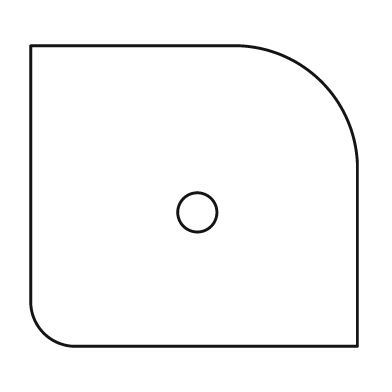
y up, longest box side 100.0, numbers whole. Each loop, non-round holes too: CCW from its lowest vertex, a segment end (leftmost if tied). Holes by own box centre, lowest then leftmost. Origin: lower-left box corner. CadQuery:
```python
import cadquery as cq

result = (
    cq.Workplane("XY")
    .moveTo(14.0, 0.0)
    .lineTo(100.0, 0.0)
    .lineTo(100.0, 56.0)
    .threePointArc((89.0, 81.0), (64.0, 92.0))
    .lineTo(0.0, 92.0)
    .lineTo(0.0, 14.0)
    .threePointArc((4.0, 4.0), (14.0, 0.0))
    .close()
    .moveTo(51.0, 41.0)
    .circle(6.0)
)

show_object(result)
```